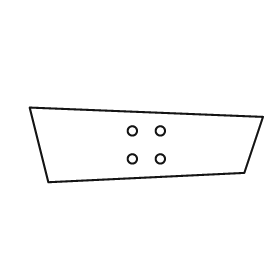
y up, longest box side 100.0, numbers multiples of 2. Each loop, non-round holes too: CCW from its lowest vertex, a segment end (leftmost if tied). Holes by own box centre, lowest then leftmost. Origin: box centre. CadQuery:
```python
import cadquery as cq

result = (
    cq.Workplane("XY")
    .moveTo(-42.0, -16.0)
    .lineTo(42.0, -12.0)
    .lineTo(50.0, 12.0)
    .lineTo(-50.0, 16.0)
    .close()
    .moveTo(-6.0, -6.0)
    .circle(2.0)
    .moveTo(6.0, -6.0)
    .circle(2.0)
    .moveTo(-6.0, 6.0)
    .circle(2.0)
    .moveTo(6.0, 6.0)
    .circle(2.0)
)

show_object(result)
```